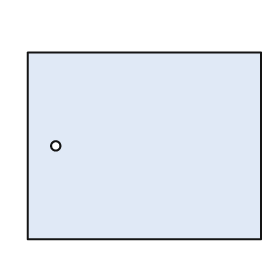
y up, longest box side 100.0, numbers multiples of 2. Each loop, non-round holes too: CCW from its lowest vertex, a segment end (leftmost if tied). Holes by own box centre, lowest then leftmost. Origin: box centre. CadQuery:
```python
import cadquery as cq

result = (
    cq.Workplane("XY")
    .moveTo(-50.0, -40.0)
    .lineTo(50.0, -40.0)
    .lineTo(50.0, 40.0)
    .lineTo(-50.0, 40.0)
    .close()
    .moveTo(-38.0, 0.0)
    .circle(2.0)
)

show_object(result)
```